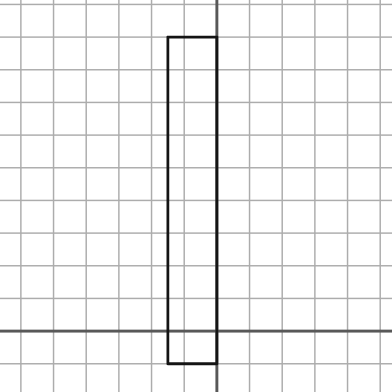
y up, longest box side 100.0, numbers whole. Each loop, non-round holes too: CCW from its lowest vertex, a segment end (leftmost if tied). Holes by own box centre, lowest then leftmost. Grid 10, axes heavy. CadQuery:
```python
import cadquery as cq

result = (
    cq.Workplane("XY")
    .moveTo(-15.0, -10.0)
    .lineTo(0.0, -10.0)
    .lineTo(0.0, 90.0)
    .lineTo(-15.0, 90.0)
    .close()
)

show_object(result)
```